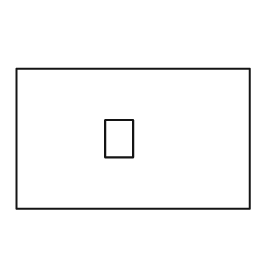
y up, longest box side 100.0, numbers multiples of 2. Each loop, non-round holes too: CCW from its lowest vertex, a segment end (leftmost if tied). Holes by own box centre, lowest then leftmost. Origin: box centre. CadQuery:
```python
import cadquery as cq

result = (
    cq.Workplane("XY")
    .moveTo(-50.0, -30.0)
    .lineTo(50.0, -30.0)
    .lineTo(50.0, 30.0)
    .lineTo(-50.0, 30.0)
    .close()
    .moveTo(-12.0, -8.0)
    .lineTo(0.0, -8.0)
    .lineTo(0.0, 8.0)
    .lineTo(-12.0, 8.0)
    .close()
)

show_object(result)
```